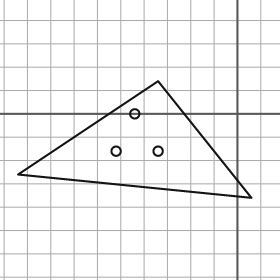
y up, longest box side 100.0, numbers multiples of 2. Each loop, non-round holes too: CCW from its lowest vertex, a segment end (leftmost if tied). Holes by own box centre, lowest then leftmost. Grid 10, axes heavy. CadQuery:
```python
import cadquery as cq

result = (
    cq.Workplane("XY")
    .moveTo(6.0, -36.0)
    .lineTo(-34.0, 14.0)
    .lineTo(-94.0, -26.0)
    .close()
    .moveTo(-52.0, -16.0)
    .circle(2.0)
    .moveTo(-34.0, -16.0)
    .circle(2.0)
    .moveTo(-44.0, 0.0)
    .circle(2.0)
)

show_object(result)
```